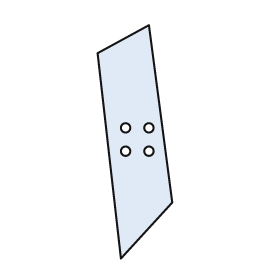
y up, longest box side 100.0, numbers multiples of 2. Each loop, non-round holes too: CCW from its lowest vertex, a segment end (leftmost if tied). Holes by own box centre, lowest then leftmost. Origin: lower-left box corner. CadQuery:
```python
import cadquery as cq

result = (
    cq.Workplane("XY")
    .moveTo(10.0, 0.0)
    .lineTo(32.0, 24.0)
    .lineTo(22.0, 100.0)
    .lineTo(0.0, 88.0)
    .close()
    .moveTo(12.0, 46.0)
    .circle(2.0)
    .moveTo(22.0, 46.0)
    .circle(2.0)
    .moveTo(12.0, 56.0)
    .circle(2.0)
    .moveTo(22.0, 56.0)
    .circle(2.0)
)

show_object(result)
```